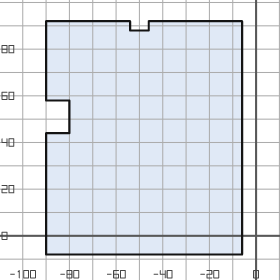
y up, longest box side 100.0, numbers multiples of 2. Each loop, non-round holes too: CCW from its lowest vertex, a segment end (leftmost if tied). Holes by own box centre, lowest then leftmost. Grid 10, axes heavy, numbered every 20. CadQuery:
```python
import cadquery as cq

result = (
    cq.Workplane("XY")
    .moveTo(-90.0, -8.0)
    .lineTo(-6.0, -8.0)
    .lineTo(-6.0, 92.0)
    .lineTo(-46.0, 92.0)
    .lineTo(-46.0, 88.0)
    .lineTo(-54.0, 88.0)
    .lineTo(-54.0, 92.0)
    .lineTo(-90.0, 92.0)
    .lineTo(-90.0, 58.0)
    .lineTo(-80.0, 58.0)
    .lineTo(-80.0, 44.0)
    .lineTo(-90.0, 44.0)
    .close()
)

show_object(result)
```